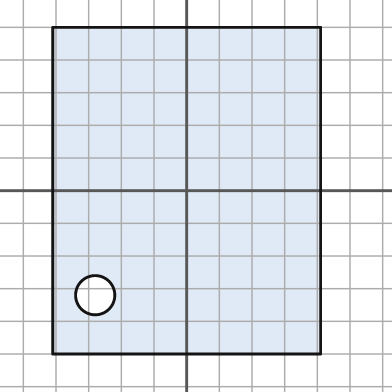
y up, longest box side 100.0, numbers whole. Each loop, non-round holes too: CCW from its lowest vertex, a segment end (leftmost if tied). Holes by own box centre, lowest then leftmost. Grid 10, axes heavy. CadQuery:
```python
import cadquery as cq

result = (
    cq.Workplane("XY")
    .moveTo(-41.0, -50.0)
    .lineTo(41.0, -50.0)
    .lineTo(41.0, 50.0)
    .lineTo(-41.0, 50.0)
    .close()
    .moveTo(-28.0, -32.0)
    .circle(6.0)
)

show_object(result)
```